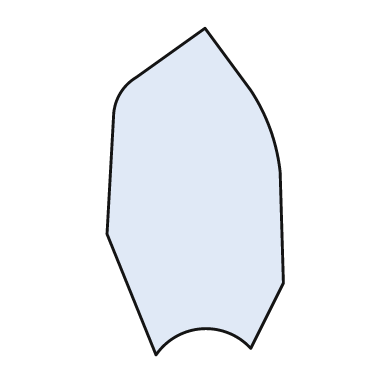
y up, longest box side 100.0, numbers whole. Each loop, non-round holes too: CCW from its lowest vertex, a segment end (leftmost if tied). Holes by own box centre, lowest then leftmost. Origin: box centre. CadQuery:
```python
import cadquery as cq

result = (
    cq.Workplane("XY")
    .moveTo(-12.0, -50.0)
    .threePointArc((2.0, -42.0), (17.0, -48.0))
    .lineTo(27.0, -28.0)
    .lineTo(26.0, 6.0)
    .threePointArc((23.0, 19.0), (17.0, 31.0))
    .lineTo(3.0, 50.0)
    .lineTo(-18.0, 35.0)
    .threePointArc((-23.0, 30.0), (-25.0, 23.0))
    .lineTo(-27.0, -13.0)
    .close()
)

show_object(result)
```